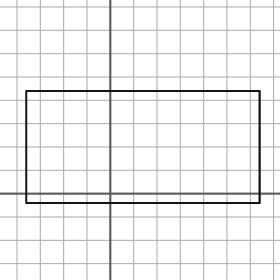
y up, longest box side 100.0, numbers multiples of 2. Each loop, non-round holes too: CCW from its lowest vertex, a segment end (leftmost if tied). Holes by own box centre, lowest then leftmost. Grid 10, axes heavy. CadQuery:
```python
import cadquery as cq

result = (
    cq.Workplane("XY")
    .moveTo(-36.0, -4.0)
    .lineTo(64.0, -4.0)
    .lineTo(64.0, 44.0)
    .lineTo(-36.0, 44.0)
    .close()
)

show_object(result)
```